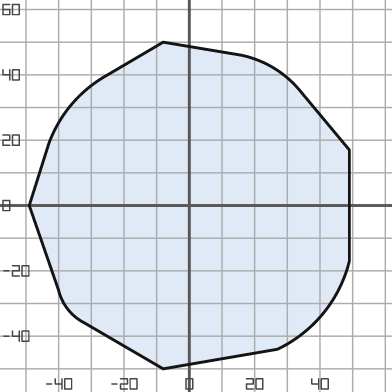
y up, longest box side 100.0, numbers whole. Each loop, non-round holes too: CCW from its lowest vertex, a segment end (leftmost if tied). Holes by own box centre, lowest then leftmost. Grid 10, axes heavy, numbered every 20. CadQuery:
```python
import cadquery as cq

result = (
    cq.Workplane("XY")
    .moveTo(-8.0, -50.0)
    .lineTo(27.0, -44.0)
    .threePointArc((41.0, -33.0), (49.0, -17.0))
    .lineTo(49.0, 17.0)
    .lineTo(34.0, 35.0)
    .threePointArc((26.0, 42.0), (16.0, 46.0))
    .lineTo(-8.0, 50.0)
    .lineTo(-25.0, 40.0)
    .threePointArc((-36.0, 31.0), (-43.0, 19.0))
    .lineTo(-49.0, 0.0)
    .lineTo(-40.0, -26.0)
    .threePointArc((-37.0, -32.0), (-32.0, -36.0))
    .close()
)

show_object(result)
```